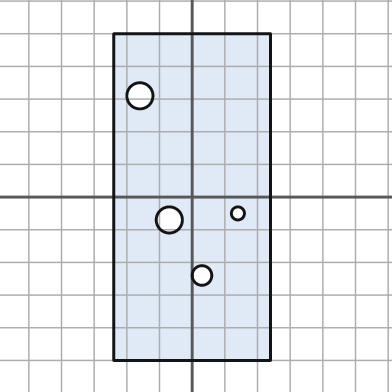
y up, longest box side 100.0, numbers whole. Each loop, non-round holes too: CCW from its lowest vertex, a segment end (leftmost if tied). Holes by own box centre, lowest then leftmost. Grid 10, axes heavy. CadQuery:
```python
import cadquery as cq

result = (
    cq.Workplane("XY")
    .moveTo(-24.0, -50.0)
    .lineTo(24.0, -50.0)
    .lineTo(24.0, 50.0)
    .lineTo(-24.0, 50.0)
    .close()
    .moveTo(3.0, -24.0)
    .circle(3.0)
    .moveTo(-7.0, -7.0)
    .circle(4.0)
    .moveTo(14.0, -5.0)
    .circle(2.0)
    .moveTo(-16.0, 31.0)
    .circle(4.0)
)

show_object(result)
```